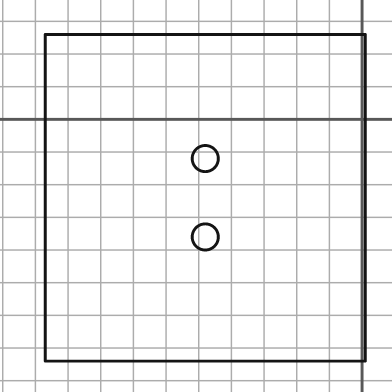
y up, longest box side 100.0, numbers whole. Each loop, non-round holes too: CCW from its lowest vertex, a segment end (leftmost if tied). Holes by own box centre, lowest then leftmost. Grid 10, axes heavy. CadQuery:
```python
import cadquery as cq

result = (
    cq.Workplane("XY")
    .moveTo(-97.0, -74.0)
    .lineTo(1.0, -74.0)
    .lineTo(1.0, 26.0)
    .lineTo(-97.0, 26.0)
    .close()
    .moveTo(-48.0, -36.0)
    .circle(4.0)
    .moveTo(-48.0, -12.0)
    .circle(4.0)
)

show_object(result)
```